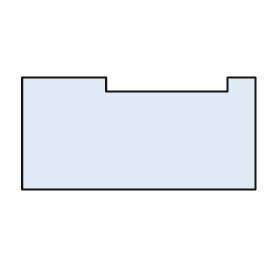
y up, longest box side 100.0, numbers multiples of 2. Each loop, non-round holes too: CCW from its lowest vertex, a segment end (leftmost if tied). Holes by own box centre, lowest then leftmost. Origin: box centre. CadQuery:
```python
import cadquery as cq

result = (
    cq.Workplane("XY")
    .moveTo(-50.0, -24.0)
    .lineTo(50.0, -24.0)
    .lineTo(50.0, 24.0)
    .lineTo(38.0, 24.0)
    .lineTo(38.0, 18.0)
    .lineTo(-14.0, 18.0)
    .lineTo(-14.0, 24.0)
    .lineTo(-50.0, 24.0)
    .close()
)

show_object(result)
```